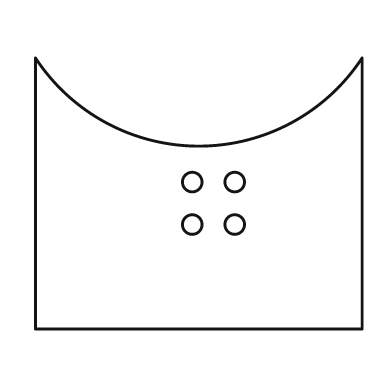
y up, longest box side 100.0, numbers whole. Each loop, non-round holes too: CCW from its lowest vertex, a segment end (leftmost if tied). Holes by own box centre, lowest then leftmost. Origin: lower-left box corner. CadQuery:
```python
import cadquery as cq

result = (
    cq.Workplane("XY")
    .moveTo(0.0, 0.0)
    .lineTo(100.0, 0.0)
    .lineTo(100.0, 83.0)
    .threePointArc((50.0, 56.0), (0.0, 83.0))
    .close()
    .moveTo(48.0, 32.0)
    .circle(3.0)
    .moveTo(61.0, 32.0)
    .circle(3.0)
    .moveTo(48.0, 45.0)
    .circle(3.0)
    .moveTo(61.0, 45.0)
    .circle(3.0)
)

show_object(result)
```